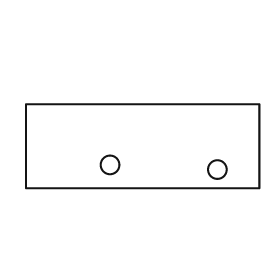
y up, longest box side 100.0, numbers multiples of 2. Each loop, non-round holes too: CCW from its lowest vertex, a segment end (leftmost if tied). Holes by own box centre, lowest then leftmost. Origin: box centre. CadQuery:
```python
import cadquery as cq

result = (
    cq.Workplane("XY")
    .moveTo(-50.0, -18.0)
    .lineTo(50.0, -18.0)
    .lineTo(50.0, 18.0)
    .lineTo(-50.0, 18.0)
    .close()
    .moveTo(32.0, -10.0)
    .circle(4.0)
    .moveTo(-14.0, -8.0)
    .circle(4.0)
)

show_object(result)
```